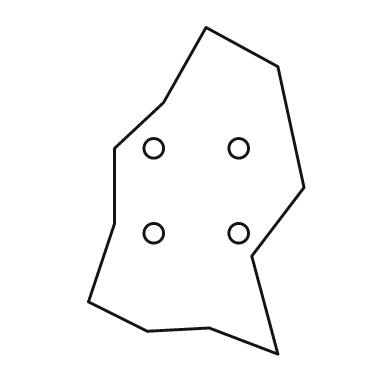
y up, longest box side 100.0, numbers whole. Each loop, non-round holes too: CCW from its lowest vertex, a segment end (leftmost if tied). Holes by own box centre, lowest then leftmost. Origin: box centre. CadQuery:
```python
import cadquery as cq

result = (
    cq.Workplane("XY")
    .moveTo(25.0, -50.0)
    .lineTo(17.0, -20.0)
    .lineTo(33.0, 1.0)
    .lineTo(25.0, 38.0)
    .lineTo(3.0, 50.0)
    .lineTo(-10.0, 27.0)
    .lineTo(-25.0, 13.0)
    .lineTo(-25.0, -10.0)
    .lineTo(-33.0, -34.0)
    .lineTo(-15.0, -43.0)
    .lineTo(4.0, -42.0)
    .close()
    .moveTo(-13.0, -13.0)
    .circle(3.0)
    .moveTo(13.0, -13.0)
    .circle(3.0)
    .moveTo(-13.0, 13.0)
    .circle(3.0)
    .moveTo(13.0, 13.0)
    .circle(3.0)
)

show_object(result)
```